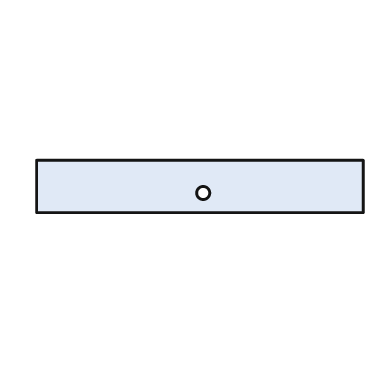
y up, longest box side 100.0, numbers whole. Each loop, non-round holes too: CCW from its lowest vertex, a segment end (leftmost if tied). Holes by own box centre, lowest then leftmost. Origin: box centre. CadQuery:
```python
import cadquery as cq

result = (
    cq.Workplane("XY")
    .moveTo(-50.0, -8.0)
    .lineTo(50.0, -8.0)
    .lineTo(50.0, 8.0)
    .lineTo(-50.0, 8.0)
    .close()
    .moveTo(1.0, -2.0)
    .circle(2.0)
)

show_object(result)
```